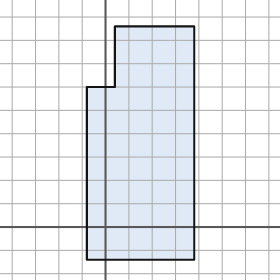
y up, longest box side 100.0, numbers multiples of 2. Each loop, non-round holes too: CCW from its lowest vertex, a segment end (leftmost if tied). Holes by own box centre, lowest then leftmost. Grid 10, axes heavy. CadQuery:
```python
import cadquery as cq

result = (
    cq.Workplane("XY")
    .moveTo(-8.0, -14.0)
    .lineTo(38.0, -14.0)
    .lineTo(38.0, 86.0)
    .lineTo(4.0, 86.0)
    .lineTo(4.0, 60.0)
    .lineTo(-8.0, 60.0)
    .close()
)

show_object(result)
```